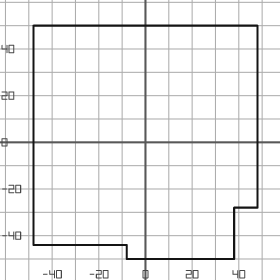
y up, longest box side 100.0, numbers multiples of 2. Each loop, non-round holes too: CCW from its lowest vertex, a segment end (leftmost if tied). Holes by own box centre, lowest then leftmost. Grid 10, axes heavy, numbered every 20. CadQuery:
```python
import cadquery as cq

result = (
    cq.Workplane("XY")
    .moveTo(-8.0, -50.0)
    .lineTo(38.0, -50.0)
    .lineTo(38.0, -28.0)
    .lineTo(48.0, -28.0)
    .lineTo(48.0, 50.0)
    .lineTo(-48.0, 50.0)
    .lineTo(-48.0, -44.0)
    .lineTo(-8.0, -44.0)
    .close()
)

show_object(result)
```